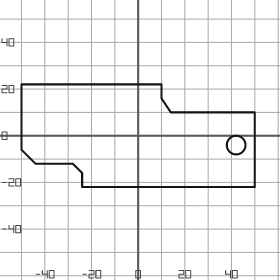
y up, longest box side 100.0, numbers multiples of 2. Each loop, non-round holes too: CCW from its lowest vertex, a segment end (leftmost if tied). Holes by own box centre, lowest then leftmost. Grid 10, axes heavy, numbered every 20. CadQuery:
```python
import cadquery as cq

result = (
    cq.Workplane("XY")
    .moveTo(-24.0, -22.0)
    .lineTo(50.0, -22.0)
    .lineTo(50.0, 10.0)
    .lineTo(14.0, 10.0)
    .lineTo(10.0, 16.0)
    .lineTo(10.0, 22.0)
    .lineTo(-50.0, 22.0)
    .lineTo(-50.0, -6.0)
    .lineTo(-44.0, -12.0)
    .lineTo(-28.0, -12.0)
    .lineTo(-24.0, -16.0)
    .close()
    .moveTo(42.0, -4.0)
    .circle(4.0)
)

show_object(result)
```